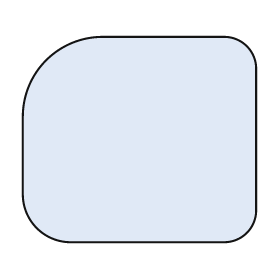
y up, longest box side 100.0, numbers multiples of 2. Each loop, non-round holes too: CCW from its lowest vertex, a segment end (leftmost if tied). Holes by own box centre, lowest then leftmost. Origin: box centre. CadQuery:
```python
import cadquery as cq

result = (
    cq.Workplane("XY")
    .moveTo(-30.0, -44.0)
    .lineTo(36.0, -44.0)
    .threePointArc((46.0, -40.0), (50.0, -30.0))
    .lineTo(50.0, 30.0)
    .threePointArc((46.0, 40.0), (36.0, 44.0))
    .lineTo(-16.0, 44.0)
    .threePointArc((-40.0, 34.0), (-50.0, 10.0))
    .lineTo(-50.0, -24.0)
    .threePointArc((-44.0, -38.0), (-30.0, -44.0))
    .close()
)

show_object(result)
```